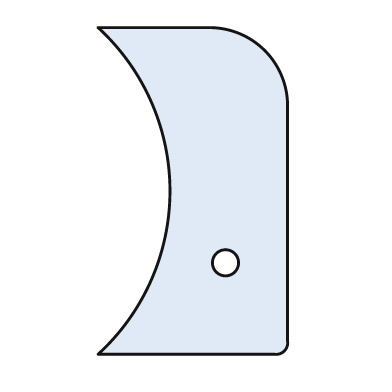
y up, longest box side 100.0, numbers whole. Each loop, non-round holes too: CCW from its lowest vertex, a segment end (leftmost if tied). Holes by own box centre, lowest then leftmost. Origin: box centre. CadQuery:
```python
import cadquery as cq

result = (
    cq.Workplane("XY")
    .moveTo(-29.0, -50.0)
    .lineTo(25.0, -50.0)
    .threePointArc((28.0, -49.0), (29.0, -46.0))
    .lineTo(29.0, 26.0)
    .threePointArc((22.0, 43.0), (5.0, 50.0))
    .lineTo(-29.0, 50.0)
    .threePointArc((-7.0, 0.0), (-29.0, -50.0))
    .close()
    .moveTo(10.0, -22.0)
    .circle(4.0)
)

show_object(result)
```